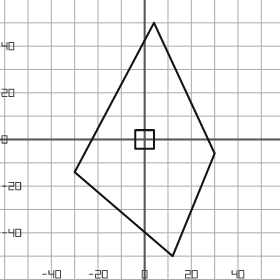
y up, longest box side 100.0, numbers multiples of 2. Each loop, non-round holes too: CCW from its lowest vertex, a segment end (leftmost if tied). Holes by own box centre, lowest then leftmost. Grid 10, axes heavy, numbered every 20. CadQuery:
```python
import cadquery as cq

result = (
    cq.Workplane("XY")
    .moveTo(12.0, -50.0)
    .lineTo(30.0, -6.0)
    .lineTo(4.0, 50.0)
    .lineTo(-30.0, -14.0)
    .close()
    .moveTo(-4.0, -4.0)
    .lineTo(4.0, -4.0)
    .lineTo(4.0, 4.0)
    .lineTo(-4.0, 4.0)
    .close()
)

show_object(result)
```